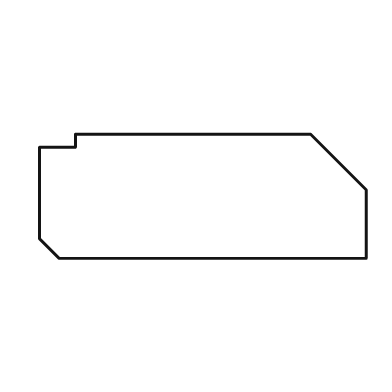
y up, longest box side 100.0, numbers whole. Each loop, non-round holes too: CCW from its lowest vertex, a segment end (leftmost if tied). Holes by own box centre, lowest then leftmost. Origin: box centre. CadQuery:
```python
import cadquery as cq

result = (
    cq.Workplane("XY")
    .moveTo(-44.0, -19.0)
    .lineTo(50.0, -19.0)
    .lineTo(50.0, 2.0)
    .lineTo(33.0, 19.0)
    .lineTo(-39.0, 19.0)
    .lineTo(-39.0, 15.0)
    .lineTo(-50.0, 15.0)
    .lineTo(-50.0, -13.0)
    .close()
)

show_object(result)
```